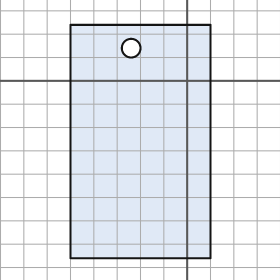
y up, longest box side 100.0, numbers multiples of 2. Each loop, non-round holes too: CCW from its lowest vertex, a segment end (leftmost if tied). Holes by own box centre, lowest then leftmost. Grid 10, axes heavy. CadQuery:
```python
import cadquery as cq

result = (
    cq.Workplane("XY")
    .moveTo(-50.0, -76.0)
    .lineTo(10.0, -76.0)
    .lineTo(10.0, 24.0)
    .lineTo(-50.0, 24.0)
    .close()
    .moveTo(-24.0, 14.0)
    .circle(4.0)
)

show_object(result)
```